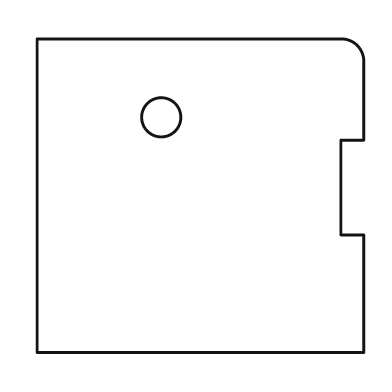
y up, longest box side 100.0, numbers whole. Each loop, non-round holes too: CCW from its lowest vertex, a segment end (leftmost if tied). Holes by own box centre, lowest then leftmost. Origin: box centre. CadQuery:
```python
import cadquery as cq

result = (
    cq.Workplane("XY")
    .moveTo(-50.0, -48.0)
    .lineTo(50.0, -48.0)
    .lineTo(50.0, -12.0)
    .lineTo(43.0, -12.0)
    .lineTo(43.0, 17.0)
    .lineTo(50.0, 17.0)
    .lineTo(50.0, 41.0)
    .threePointArc((48.0, 46.0), (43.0, 48.0))
    .lineTo(-50.0, 48.0)
    .close()
    .moveTo(-12.0, 24.0)
    .circle(6.0)
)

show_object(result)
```